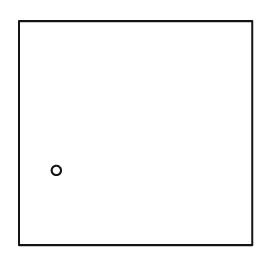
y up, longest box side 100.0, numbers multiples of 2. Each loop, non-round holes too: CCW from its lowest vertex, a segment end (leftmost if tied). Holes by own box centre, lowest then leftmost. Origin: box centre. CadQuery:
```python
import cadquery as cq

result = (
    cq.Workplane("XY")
    .moveTo(-50.0, -48.0)
    .lineTo(50.0, -48.0)
    .lineTo(50.0, 48.0)
    .lineTo(-50.0, 48.0)
    .close()
    .moveTo(-34.0, -16.0)
    .circle(2.0)
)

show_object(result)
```